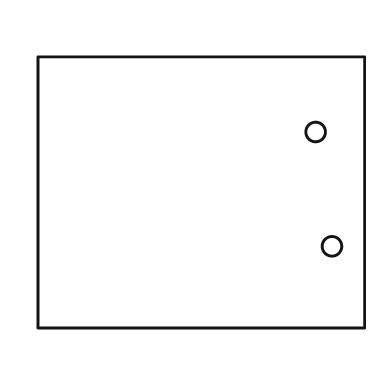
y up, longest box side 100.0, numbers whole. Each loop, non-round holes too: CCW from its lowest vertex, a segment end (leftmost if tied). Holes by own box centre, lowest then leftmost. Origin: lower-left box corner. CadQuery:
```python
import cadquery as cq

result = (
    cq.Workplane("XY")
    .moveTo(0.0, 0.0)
    .lineTo(100.0, 0.0)
    .lineTo(100.0, 83.0)
    .lineTo(0.0, 83.0)
    .close()
    .moveTo(90.0, 25.0)
    .circle(3.0)
    .moveTo(85.0, 60.0)
    .circle(3.0)
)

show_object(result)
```